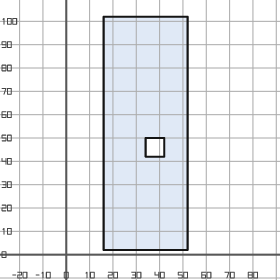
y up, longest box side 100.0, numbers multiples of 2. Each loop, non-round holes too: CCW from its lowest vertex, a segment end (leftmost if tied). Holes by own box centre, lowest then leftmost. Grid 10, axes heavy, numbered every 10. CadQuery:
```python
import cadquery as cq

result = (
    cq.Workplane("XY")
    .moveTo(16.0, 2.0)
    .lineTo(52.0, 2.0)
    .lineTo(52.0, 102.0)
    .lineTo(16.0, 102.0)
    .close()
    .moveTo(34.0, 42.0)
    .lineTo(42.0, 42.0)
    .lineTo(42.0, 50.0)
    .lineTo(34.0, 50.0)
    .close()
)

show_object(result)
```